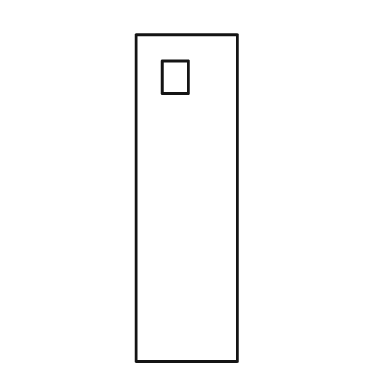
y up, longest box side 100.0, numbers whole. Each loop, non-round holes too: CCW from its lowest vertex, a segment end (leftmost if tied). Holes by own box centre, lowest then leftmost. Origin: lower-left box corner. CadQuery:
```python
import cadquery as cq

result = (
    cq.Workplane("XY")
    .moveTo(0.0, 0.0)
    .lineTo(31.0, 0.0)
    .lineTo(31.0, 100.0)
    .lineTo(0.0, 100.0)
    .close()
    .moveTo(8.0, 82.0)
    .lineTo(16.0, 82.0)
    .lineTo(16.0, 92.0)
    .lineTo(8.0, 92.0)
    .close()
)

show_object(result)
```